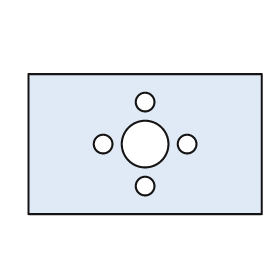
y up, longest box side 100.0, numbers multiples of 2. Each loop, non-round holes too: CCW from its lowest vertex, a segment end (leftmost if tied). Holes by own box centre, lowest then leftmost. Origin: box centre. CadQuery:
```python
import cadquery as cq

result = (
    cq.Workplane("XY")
    .moveTo(-50.0, -30.0)
    .lineTo(50.0, -30.0)
    .lineTo(50.0, 30.0)
    .lineTo(-50.0, 30.0)
    .close()
    .moveTo(0.0, -18.0)
    .circle(4.0)
    .moveTo(-18.0, 0.0)
    .circle(4.0)
    .moveTo(0.0, 0.0)
    .circle(10.0)
    .moveTo(18.0, 0.0)
    .circle(4.0)
    .moveTo(0.0, 18.0)
    .circle(4.0)
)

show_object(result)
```